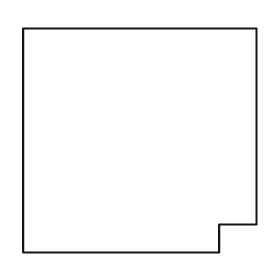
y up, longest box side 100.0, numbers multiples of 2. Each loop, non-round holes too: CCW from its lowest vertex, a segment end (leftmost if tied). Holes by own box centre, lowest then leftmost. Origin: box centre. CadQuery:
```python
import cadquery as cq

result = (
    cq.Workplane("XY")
    .moveTo(-50.0, -48.0)
    .lineTo(34.0, -48.0)
    .lineTo(34.0, -36.0)
    .lineTo(50.0, -36.0)
    .lineTo(50.0, 48.0)
    .lineTo(-50.0, 48.0)
    .close()
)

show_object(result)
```